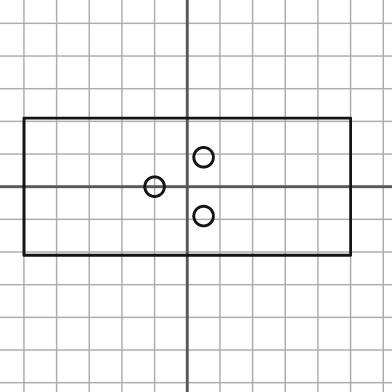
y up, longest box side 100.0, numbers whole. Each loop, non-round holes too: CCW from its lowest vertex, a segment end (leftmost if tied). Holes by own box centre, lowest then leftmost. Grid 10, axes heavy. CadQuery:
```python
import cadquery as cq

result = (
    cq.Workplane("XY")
    .moveTo(-50.0, -21.0)
    .lineTo(50.0, -21.0)
    .lineTo(50.0, 21.0)
    .lineTo(-50.0, 21.0)
    .close()
    .moveTo(5.0, -9.0)
    .circle(3.0)
    .moveTo(-10.0, 0.0)
    .circle(3.0)
    .moveTo(5.0, 9.0)
    .circle(3.0)
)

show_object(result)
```